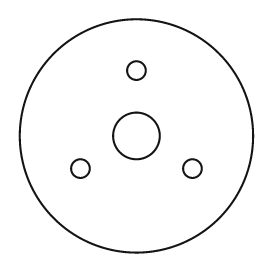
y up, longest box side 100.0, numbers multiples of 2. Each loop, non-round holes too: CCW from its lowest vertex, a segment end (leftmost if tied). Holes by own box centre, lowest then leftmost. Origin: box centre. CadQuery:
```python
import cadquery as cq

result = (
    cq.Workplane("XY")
    .moveTo(0.0, 0.0)
    .circle(50.0)
    .moveTo(-24.0, -14.0)
    .circle(4.0)
    .moveTo(24.0, -14.0)
    .circle(4.0)
    .moveTo(0.0, 0.0)
    .circle(10.0)
    .moveTo(0.0, 28.0)
    .circle(4.0)
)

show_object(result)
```